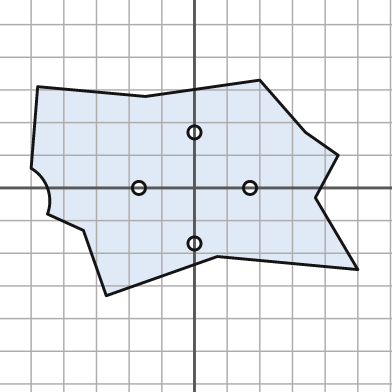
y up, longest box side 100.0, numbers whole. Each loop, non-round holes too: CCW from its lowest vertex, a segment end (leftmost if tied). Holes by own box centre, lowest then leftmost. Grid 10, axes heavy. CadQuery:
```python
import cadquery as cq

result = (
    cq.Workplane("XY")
    .moveTo(-27.0, -33.0)
    .lineTo(7.0, -21.0)
    .lineTo(50.0, -25.0)
    .lineTo(37.0, -3.0)
    .lineTo(44.0, 10.0)
    .lineTo(34.0, 17.0)
    .lineTo(20.0, 33.0)
    .lineTo(-15.0, 28.0)
    .lineTo(-48.0, 31.0)
    .lineTo(-50.0, 6.0)
    .threePointArc((-45.0, 0.0), (-45.0, -8.0))
    .lineTo(-34.0, -13.0)
    .close()
    .moveTo(0.0, -17.0)
    .circle(2.0)
    .moveTo(-17.0, 0.0)
    .circle(2.0)
    .moveTo(17.0, 0.0)
    .circle(2.0)
    .moveTo(0.0, 17.0)
    .circle(2.0)
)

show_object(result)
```